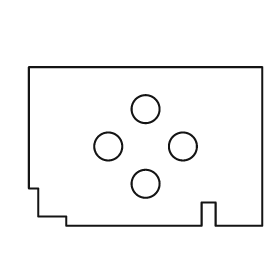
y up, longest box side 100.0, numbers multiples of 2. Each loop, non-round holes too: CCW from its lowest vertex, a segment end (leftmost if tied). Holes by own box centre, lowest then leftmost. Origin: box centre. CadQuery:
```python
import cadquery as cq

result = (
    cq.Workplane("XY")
    .moveTo(-34.0, -34.0)
    .lineTo(24.0, -34.0)
    .lineTo(24.0, -24.0)
    .lineTo(30.0, -24.0)
    .lineTo(30.0, -34.0)
    .lineTo(50.0, -34.0)
    .lineTo(50.0, 34.0)
    .lineTo(-50.0, 34.0)
    .lineTo(-50.0, -18.0)
    .lineTo(-46.0, -18.0)
    .lineTo(-46.0, -30.0)
    .lineTo(-34.0, -30.0)
    .close()
    .moveTo(0.0, -16.0)
    .circle(6.0)
    .moveTo(-16.0, 0.0)
    .circle(6.0)
    .moveTo(16.0, 0.0)
    .circle(6.0)
    .moveTo(0.0, 16.0)
    .circle(6.0)
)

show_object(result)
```